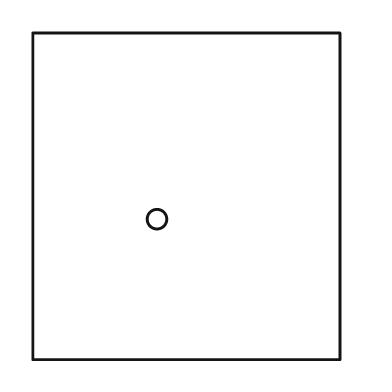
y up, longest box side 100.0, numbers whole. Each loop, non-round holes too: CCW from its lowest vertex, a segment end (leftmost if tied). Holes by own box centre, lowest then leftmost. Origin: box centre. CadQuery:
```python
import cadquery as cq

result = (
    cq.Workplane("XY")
    .moveTo(-47.0, -50.0)
    .lineTo(47.0, -50.0)
    .lineTo(47.0, 50.0)
    .lineTo(-47.0, 50.0)
    .close()
    .moveTo(-9.0, -7.0)
    .circle(3.0)
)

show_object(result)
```